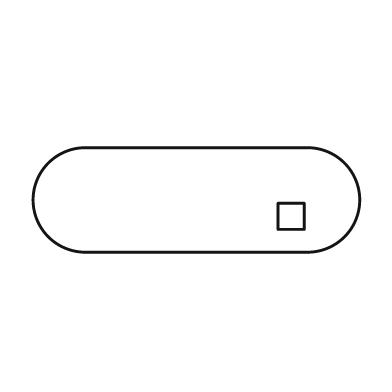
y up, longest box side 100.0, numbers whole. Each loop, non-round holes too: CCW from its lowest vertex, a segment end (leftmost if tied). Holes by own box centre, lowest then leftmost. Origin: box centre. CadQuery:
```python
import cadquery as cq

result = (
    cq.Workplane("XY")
    .moveTo(-34.0, -16.0)
    .lineTo(34.0, -16.0)
    .threePointArc((50.0, 0.0), (34.0, 16.0))
    .lineTo(-34.0, 16.0)
    .threePointArc((-50.0, 0.0), (-34.0, -16.0))
    .close()
    .moveTo(25.0, -9.0)
    .lineTo(33.0, -9.0)
    .lineTo(33.0, -1.0)
    .lineTo(25.0, -1.0)
    .close()
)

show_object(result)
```